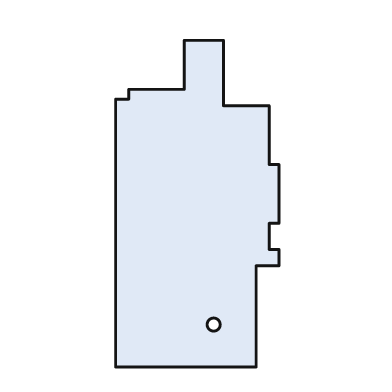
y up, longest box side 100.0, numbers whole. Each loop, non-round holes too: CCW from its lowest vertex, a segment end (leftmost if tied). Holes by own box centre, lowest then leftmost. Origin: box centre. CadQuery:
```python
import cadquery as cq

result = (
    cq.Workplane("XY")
    .moveTo(-25.0, -50.0)
    .lineTo(18.0, -50.0)
    .lineTo(18.0, -19.0)
    .lineTo(25.0, -19.0)
    .lineTo(25.0, -14.0)
    .lineTo(22.0, -14.0)
    .lineTo(22.0, -6.0)
    .lineTo(25.0, -6.0)
    .lineTo(25.0, 12.0)
    .lineTo(22.0, 12.0)
    .lineTo(22.0, 30.0)
    .lineTo(8.0, 30.0)
    .lineTo(8.0, 50.0)
    .lineTo(-4.0, 50.0)
    .lineTo(-4.0, 35.0)
    .lineTo(-21.0, 35.0)
    .lineTo(-21.0, 32.0)
    .lineTo(-25.0, 32.0)
    .close()
    .moveTo(5.0, -37.0)
    .circle(2.0)
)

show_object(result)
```